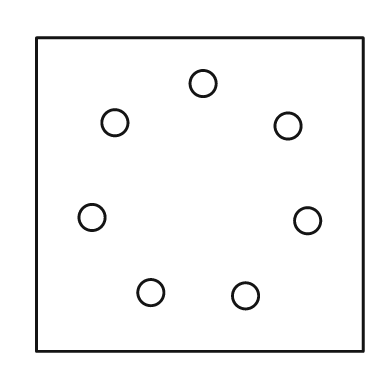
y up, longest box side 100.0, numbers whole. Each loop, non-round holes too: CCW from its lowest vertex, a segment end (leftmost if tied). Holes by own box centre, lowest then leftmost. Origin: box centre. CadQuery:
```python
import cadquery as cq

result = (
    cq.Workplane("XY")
    .moveTo(-50.0, -48.0)
    .lineTo(50.0, -48.0)
    .lineTo(50.0, 48.0)
    .lineTo(-50.0, 48.0)
    .close()
    .moveTo(14.0, -31.0)
    .circle(4.0)
    .moveTo(-15.0, -30.0)
    .circle(4.0)
    .moveTo(33.0, -8.0)
    .circle(4.0)
    .moveTo(-33.0, -7.0)
    .circle(4.0)
    .moveTo(27.0, 21.0)
    .circle(4.0)
    .moveTo(-26.0, 22.0)
    .circle(4.0)
    .moveTo(1.0, 34.0)
    .circle(4.0)
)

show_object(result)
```